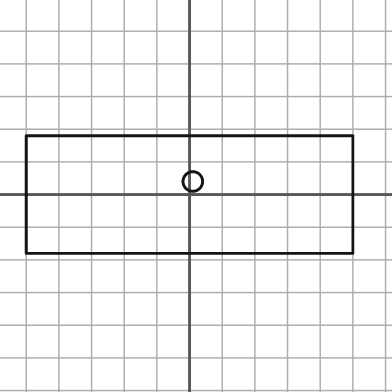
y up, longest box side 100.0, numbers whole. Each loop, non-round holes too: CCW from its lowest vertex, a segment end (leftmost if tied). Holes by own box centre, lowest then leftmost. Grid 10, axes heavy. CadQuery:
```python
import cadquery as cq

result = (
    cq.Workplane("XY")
    .moveTo(-50.0, -18.0)
    .lineTo(50.0, -18.0)
    .lineTo(50.0, 18.0)
    .lineTo(-50.0, 18.0)
    .close()
    .moveTo(1.0, 4.0)
    .circle(3.0)
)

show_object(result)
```